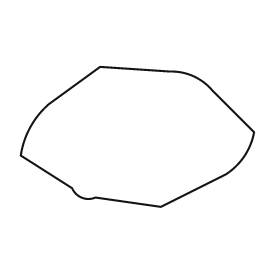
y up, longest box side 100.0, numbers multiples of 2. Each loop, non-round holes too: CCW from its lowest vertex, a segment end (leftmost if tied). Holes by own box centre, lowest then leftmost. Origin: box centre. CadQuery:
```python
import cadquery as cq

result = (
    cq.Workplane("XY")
    .moveTo(10.0, -30.0)
    .lineTo(38.0, -16.0)
    .threePointArc((46.0, -8.0), (50.0, 2.0))
    .lineTo(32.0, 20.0)
    .threePointArc((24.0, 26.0), (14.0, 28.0))
    .lineTo(-16.0, 30.0)
    .lineTo(-38.0, 14.0)
    .threePointArc((-46.0, 4.0), (-50.0, -8.0))
    .lineTo(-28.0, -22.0)
    .threePointArc((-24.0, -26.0), (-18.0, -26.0))
    .close()
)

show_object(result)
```